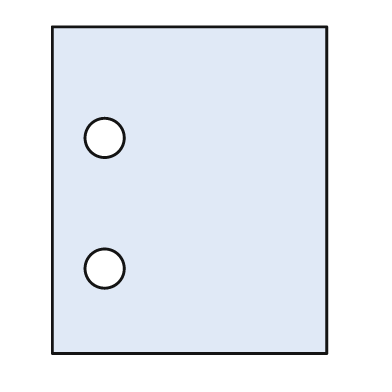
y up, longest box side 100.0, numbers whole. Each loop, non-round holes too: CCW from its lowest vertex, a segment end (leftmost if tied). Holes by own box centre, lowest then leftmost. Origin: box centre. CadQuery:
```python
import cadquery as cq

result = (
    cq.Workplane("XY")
    .moveTo(-42.0, -50.0)
    .lineTo(42.0, -50.0)
    .lineTo(42.0, 50.0)
    .lineTo(-42.0, 50.0)
    .close()
    .moveTo(-26.0, -24.0)
    .circle(6.0)
    .moveTo(-26.0, 16.0)
    .circle(6.0)
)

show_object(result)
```